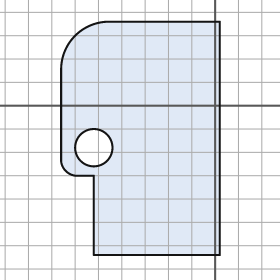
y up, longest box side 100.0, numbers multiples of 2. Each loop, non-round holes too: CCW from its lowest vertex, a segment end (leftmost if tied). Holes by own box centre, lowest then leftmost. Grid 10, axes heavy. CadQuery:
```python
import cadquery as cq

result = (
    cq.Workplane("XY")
    .moveTo(-52.0, -64.0)
    .lineTo(2.0, -64.0)
    .lineTo(2.0, 36.0)
    .lineTo(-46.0, 36.0)
    .threePointArc((-60.0, 30.0), (-66.0, 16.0))
    .lineTo(-66.0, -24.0)
    .threePointArc((-64.0, -28.0), (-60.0, -30.0))
    .lineTo(-52.0, -30.0)
    .close()
    .moveTo(-52.0, -18.0)
    .circle(8.0)
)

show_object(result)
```